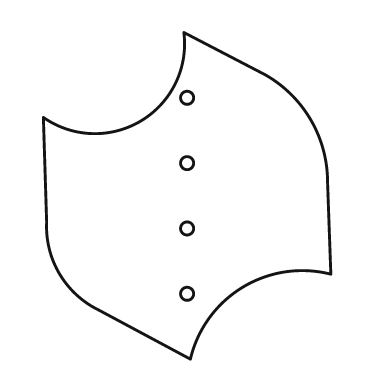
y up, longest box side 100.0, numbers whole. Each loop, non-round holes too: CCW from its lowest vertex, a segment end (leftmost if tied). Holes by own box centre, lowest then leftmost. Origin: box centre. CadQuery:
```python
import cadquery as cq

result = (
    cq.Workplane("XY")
    .moveTo(1.0, -50.0)
    .threePointArc((17.0, -28.0), (44.0, -24.0))
    .lineTo(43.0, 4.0)
    .threePointArc((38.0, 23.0), (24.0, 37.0))
    .lineTo(-1.0, 50.0)
    .threePointArc((-14.0, 23.0), (-44.0, 24.0))
    .lineTo(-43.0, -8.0)
    .threePointArc((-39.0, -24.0), (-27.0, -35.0))
    .close()
    .moveTo(0.0, -30.0)
    .circle(2.0)
    .moveTo(0.0, -10.0)
    .circle(2.0)
    .moveTo(0.0, 10.0)
    .circle(2.0)
    .moveTo(0.0, 30.0)
    .circle(2.0)
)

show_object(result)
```